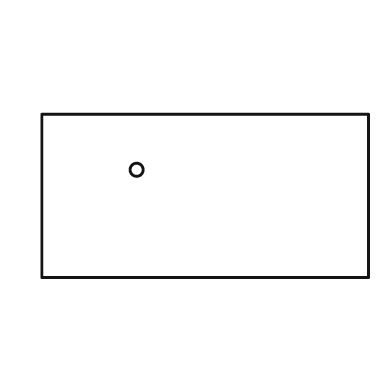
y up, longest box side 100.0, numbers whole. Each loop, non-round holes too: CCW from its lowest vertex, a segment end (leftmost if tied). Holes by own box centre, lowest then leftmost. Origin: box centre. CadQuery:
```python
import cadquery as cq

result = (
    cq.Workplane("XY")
    .moveTo(-50.0, -25.0)
    .lineTo(50.0, -25.0)
    .lineTo(50.0, 25.0)
    .lineTo(-50.0, 25.0)
    .close()
    .moveTo(-21.0, 8.0)
    .circle(2.0)
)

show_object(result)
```